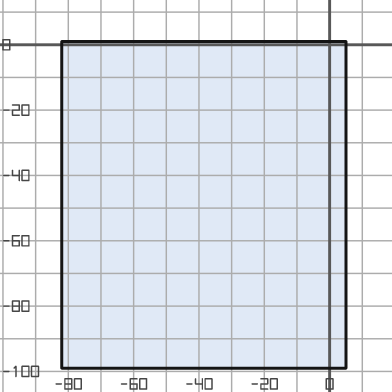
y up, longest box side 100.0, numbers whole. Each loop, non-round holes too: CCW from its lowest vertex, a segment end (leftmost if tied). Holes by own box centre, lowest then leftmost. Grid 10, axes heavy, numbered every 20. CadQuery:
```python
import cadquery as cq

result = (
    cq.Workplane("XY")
    .moveTo(-82.0, -99.0)
    .lineTo(5.0, -99.0)
    .lineTo(5.0, 1.0)
    .lineTo(-82.0, 1.0)
    .close()
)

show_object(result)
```